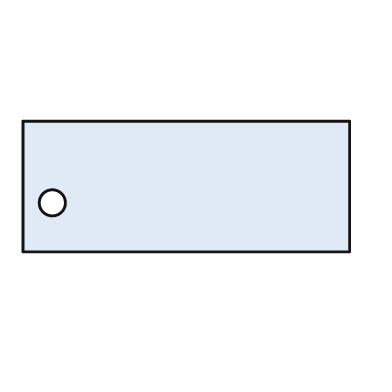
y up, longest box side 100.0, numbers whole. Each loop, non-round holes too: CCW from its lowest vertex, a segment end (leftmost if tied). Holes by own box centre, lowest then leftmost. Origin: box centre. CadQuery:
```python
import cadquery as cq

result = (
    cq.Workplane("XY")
    .moveTo(-50.0, -20.0)
    .lineTo(50.0, -20.0)
    .lineTo(50.0, 20.0)
    .lineTo(-50.0, 20.0)
    .close()
    .moveTo(-41.0, -5.0)
    .circle(4.0)
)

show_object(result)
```